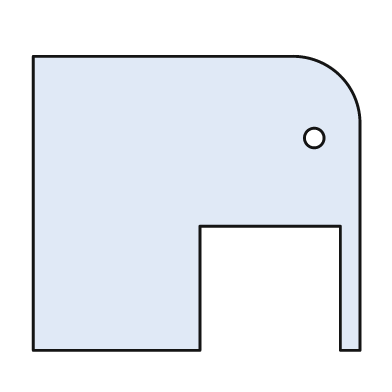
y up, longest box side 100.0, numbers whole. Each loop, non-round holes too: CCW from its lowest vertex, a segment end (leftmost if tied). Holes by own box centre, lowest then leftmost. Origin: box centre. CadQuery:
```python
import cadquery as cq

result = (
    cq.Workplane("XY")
    .moveTo(-50.0, -45.0)
    .lineTo(1.0, -45.0)
    .lineTo(1.0, -7.0)
    .lineTo(44.0, -7.0)
    .lineTo(44.0, -45.0)
    .lineTo(50.0, -45.0)
    .lineTo(50.0, 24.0)
    .threePointArc((44.0, 39.0), (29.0, 45.0))
    .lineTo(-50.0, 45.0)
    .close()
    .moveTo(36.0, 20.0)
    .circle(3.0)
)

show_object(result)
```